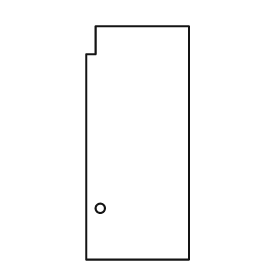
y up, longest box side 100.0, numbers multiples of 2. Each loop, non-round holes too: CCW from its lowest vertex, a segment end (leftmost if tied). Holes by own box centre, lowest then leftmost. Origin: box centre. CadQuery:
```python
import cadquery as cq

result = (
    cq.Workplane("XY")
    .moveTo(-22.0, -50.0)
    .lineTo(22.0, -50.0)
    .lineTo(22.0, 50.0)
    .lineTo(-18.0, 50.0)
    .lineTo(-18.0, 38.0)
    .lineTo(-22.0, 38.0)
    .close()
    .moveTo(-16.0, -28.0)
    .circle(2.0)
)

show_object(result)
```